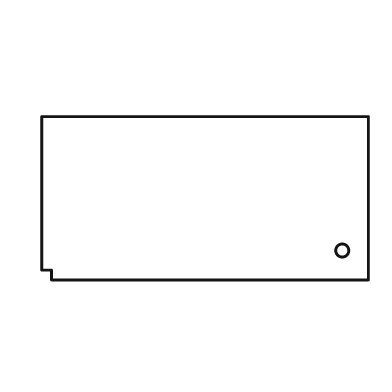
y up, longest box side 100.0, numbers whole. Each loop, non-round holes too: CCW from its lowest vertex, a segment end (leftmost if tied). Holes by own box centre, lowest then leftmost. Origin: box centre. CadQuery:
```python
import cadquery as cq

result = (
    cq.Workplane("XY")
    .moveTo(-47.0, -25.0)
    .lineTo(50.0, -25.0)
    .lineTo(50.0, 25.0)
    .lineTo(-50.0, 25.0)
    .lineTo(-50.0, -22.0)
    .lineTo(-47.0, -22.0)
    .close()
    .moveTo(42.0, -16.0)
    .circle(2.0)
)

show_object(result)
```